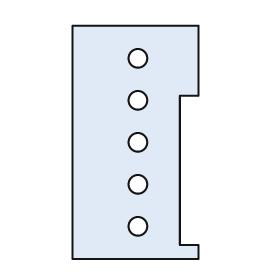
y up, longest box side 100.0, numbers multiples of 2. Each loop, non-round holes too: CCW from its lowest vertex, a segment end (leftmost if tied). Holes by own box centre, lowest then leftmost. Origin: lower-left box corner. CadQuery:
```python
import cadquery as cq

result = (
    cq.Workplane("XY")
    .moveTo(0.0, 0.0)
    .lineTo(54.0, 0.0)
    .lineTo(54.0, 6.0)
    .lineTo(46.0, 6.0)
    .lineTo(46.0, 70.0)
    .lineTo(54.0, 70.0)
    .lineTo(54.0, 100.0)
    .lineTo(0.0, 100.0)
    .close()
    .moveTo(28.0, 14.0)
    .circle(4.0)
    .moveTo(28.0, 32.0)
    .circle(4.0)
    .moveTo(28.0, 50.0)
    .circle(4.0)
    .moveTo(28.0, 68.0)
    .circle(4.0)
    .moveTo(28.0, 86.0)
    .circle(4.0)
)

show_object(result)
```